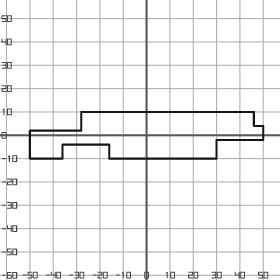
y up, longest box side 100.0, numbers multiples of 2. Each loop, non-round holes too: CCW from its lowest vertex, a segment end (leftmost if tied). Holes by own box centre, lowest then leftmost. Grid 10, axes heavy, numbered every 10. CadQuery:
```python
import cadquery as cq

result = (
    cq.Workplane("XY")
    .moveTo(-50.0, -10.0)
    .lineTo(-36.0, -10.0)
    .lineTo(-36.0, -4.0)
    .lineTo(-16.0, -4.0)
    .lineTo(-16.0, -10.0)
    .lineTo(30.0, -10.0)
    .lineTo(30.0, -2.0)
    .lineTo(50.0, -2.0)
    .lineTo(50.0, 4.0)
    .lineTo(46.0, 4.0)
    .lineTo(46.0, 10.0)
    .lineTo(-28.0, 10.0)
    .lineTo(-28.0, 2.0)
    .lineTo(-50.0, 2.0)
    .close()
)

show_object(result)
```